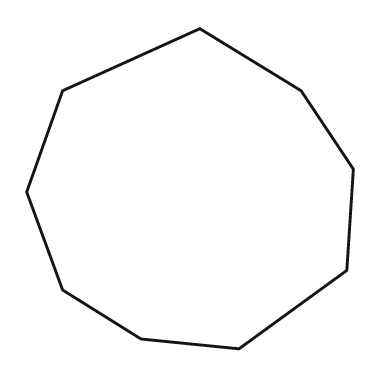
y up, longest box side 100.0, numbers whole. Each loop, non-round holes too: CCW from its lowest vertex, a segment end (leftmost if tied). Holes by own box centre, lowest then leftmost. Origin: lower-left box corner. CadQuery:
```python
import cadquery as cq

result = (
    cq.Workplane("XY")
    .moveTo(65.0, 0.0)
    .lineTo(98.0, 24.0)
    .lineTo(100.0, 55.0)
    .lineTo(84.0, 79.0)
    .lineTo(53.0, 98.0)
    .lineTo(11.0, 79.0)
    .lineTo(0.0, 48.0)
    .lineTo(11.0, 18.0)
    .lineTo(35.0, 3.0)
    .close()
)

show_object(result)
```